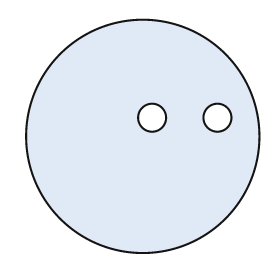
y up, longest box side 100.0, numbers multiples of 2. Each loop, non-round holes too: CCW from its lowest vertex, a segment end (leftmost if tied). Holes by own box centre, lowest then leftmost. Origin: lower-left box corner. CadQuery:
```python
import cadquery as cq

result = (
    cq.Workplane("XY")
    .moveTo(50.0, 50.0)
    .circle(50.0)
    .moveTo(54.0, 58.0)
    .circle(6.0)
    .moveTo(82.0, 58.0)
    .circle(6.0)
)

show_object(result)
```